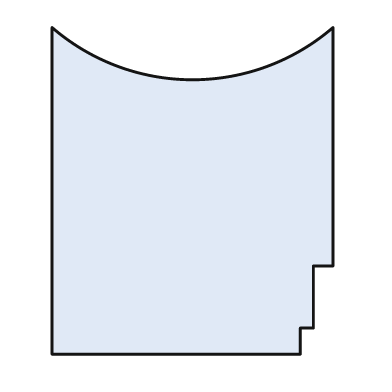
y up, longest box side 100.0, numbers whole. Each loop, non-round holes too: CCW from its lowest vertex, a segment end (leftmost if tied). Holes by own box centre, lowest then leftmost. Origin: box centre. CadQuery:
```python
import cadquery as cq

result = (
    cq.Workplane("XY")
    .moveTo(-43.0, -50.0)
    .lineTo(33.0, -50.0)
    .lineTo(33.0, -42.0)
    .lineTo(37.0, -42.0)
    .lineTo(37.0, -23.0)
    .lineTo(43.0, -23.0)
    .lineTo(43.0, 50.0)
    .threePointArc((0.0, 34.0), (-43.0, 50.0))
    .close()
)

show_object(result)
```